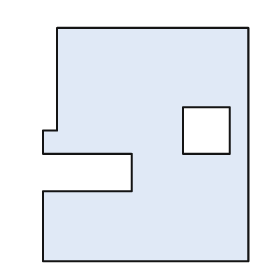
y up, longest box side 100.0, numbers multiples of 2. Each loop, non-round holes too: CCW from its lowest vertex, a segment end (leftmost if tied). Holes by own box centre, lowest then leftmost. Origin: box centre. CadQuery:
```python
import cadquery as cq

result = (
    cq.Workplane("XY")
    .moveTo(-44.0, -50.0)
    .lineTo(44.0, -50.0)
    .lineTo(44.0, 50.0)
    .lineTo(-38.0, 50.0)
    .lineTo(-38.0, 6.0)
    .lineTo(-44.0, 6.0)
    .lineTo(-44.0, -4.0)
    .lineTo(-6.0, -4.0)
    .lineTo(-6.0, -20.0)
    .lineTo(-44.0, -20.0)
    .close()
    .moveTo(16.0, -4.0)
    .lineTo(36.0, -4.0)
    .lineTo(36.0, 16.0)
    .lineTo(16.0, 16.0)
    .close()
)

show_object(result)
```